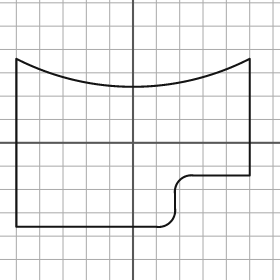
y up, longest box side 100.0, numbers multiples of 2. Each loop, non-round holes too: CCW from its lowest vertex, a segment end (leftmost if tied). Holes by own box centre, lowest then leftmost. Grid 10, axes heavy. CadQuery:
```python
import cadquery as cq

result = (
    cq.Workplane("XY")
    .moveTo(-50.0, -36.0)
    .lineTo(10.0, -36.0)
    .threePointArc((16.0, -34.0), (18.0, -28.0))
    .lineTo(18.0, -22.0)
    .threePointArc((20.0, -16.0), (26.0, -14.0))
    .lineTo(50.0, -14.0)
    .lineTo(50.0, 36.0)
    .threePointArc((0.0, 24.0), (-50.0, 36.0))
    .close()
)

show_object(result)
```